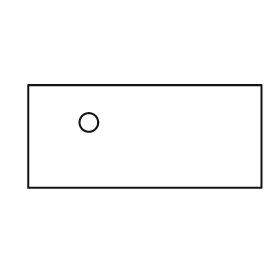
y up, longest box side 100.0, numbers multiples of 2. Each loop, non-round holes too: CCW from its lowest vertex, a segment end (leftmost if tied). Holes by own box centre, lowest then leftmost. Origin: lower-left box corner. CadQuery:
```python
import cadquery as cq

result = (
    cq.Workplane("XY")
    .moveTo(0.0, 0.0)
    .lineTo(100.0, 0.0)
    .lineTo(100.0, 44.0)
    .lineTo(0.0, 44.0)
    .close()
    .moveTo(26.0, 28.0)
    .circle(4.0)
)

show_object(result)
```